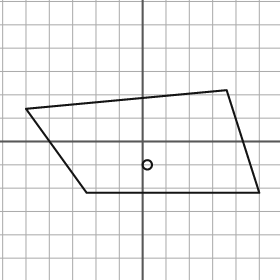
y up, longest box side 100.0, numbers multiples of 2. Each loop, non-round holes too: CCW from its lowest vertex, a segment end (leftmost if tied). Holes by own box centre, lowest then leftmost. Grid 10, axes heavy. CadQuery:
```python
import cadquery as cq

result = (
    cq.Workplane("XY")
    .moveTo(-24.0, -22.0)
    .lineTo(50.0, -22.0)
    .lineTo(36.0, 22.0)
    .lineTo(-50.0, 14.0)
    .close()
    .moveTo(2.0, -10.0)
    .circle(2.0)
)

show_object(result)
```